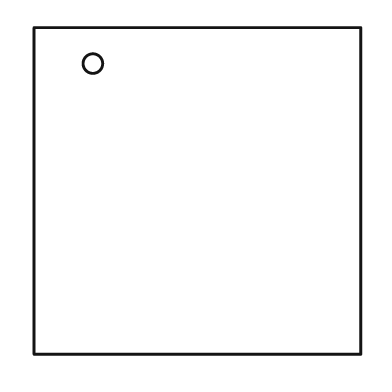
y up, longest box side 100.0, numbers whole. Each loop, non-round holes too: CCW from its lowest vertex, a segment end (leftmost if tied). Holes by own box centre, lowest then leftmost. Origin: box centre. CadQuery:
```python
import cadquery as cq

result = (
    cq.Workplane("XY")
    .moveTo(-50.0, -50.0)
    .lineTo(50.0, -50.0)
    .lineTo(50.0, 50.0)
    .lineTo(-50.0, 50.0)
    .close()
    .moveTo(-32.0, 39.0)
    .circle(3.0)
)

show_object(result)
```